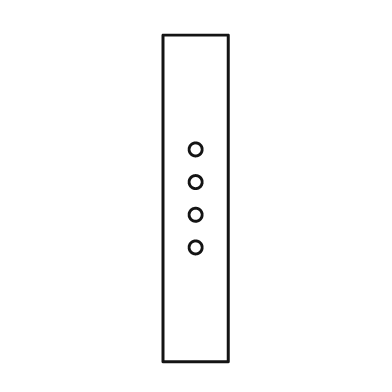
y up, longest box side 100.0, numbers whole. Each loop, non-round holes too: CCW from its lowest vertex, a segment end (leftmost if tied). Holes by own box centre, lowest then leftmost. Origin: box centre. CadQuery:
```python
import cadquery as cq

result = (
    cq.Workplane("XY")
    .moveTo(-10.0, -50.0)
    .lineTo(10.0, -50.0)
    .lineTo(10.0, 50.0)
    .lineTo(-10.0, 50.0)
    .close()
    .moveTo(0.0, -15.0)
    .circle(2.0)
    .moveTo(0.0, -5.0)
    .circle(2.0)
    .moveTo(0.0, 5.0)
    .circle(2.0)
    .moveTo(0.0, 15.0)
    .circle(2.0)
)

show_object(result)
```